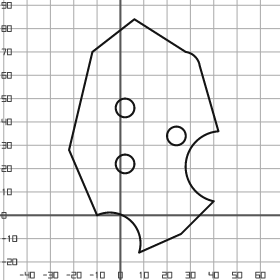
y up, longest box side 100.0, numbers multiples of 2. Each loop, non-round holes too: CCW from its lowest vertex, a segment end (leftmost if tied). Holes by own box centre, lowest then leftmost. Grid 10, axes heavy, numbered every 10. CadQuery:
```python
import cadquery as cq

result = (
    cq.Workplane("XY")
    .moveTo(8.0, -16.0)
    .lineTo(26.0, -8.0)
    .lineTo(40.0, 6.0)
    .threePointArc((28.0, 22.0), (42.0, 36.0))
    .lineTo(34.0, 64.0)
    .threePointArc((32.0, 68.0), (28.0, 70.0))
    .lineTo(6.0, 84.0)
    .lineTo(-12.0, 70.0)
    .lineTo(-22.0, 28.0)
    .lineTo(-10.0, 0.0)
    .threePointArc((4.0, -2.0), (8.0, -16.0))
    .close()
    .moveTo(2.0, 22.0)
    .circle(4.0)
    .moveTo(24.0, 34.0)
    .circle(4.0)
    .moveTo(2.0, 46.0)
    .circle(4.0)
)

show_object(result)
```